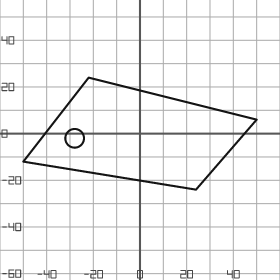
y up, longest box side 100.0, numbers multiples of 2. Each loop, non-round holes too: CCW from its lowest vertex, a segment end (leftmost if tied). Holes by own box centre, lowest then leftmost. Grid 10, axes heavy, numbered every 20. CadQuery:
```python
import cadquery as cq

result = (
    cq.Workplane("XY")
    .moveTo(24.0, -24.0)
    .lineTo(50.0, 6.0)
    .lineTo(-22.0, 24.0)
    .lineTo(-50.0, -12.0)
    .close()
    .moveTo(-28.0, -2.0)
    .circle(4.0)
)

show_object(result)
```